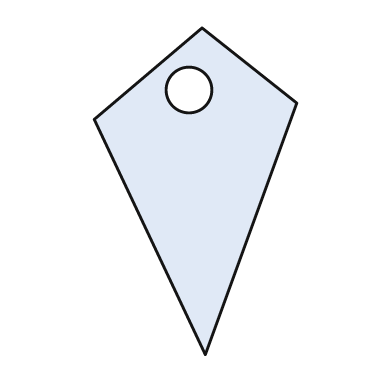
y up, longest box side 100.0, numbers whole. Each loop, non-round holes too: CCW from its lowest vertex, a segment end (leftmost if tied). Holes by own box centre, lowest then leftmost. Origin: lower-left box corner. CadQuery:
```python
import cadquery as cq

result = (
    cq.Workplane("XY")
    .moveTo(34.0, 0.0)
    .lineTo(62.0, 77.0)
    .lineTo(33.0, 100.0)
    .lineTo(0.0, 72.0)
    .close()
    .moveTo(29.0, 81.0)
    .circle(7.0)
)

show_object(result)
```